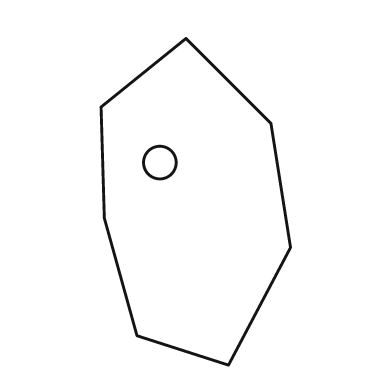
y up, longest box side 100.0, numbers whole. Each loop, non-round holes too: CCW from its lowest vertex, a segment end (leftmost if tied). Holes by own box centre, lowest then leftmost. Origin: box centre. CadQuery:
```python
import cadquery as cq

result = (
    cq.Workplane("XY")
    .moveTo(10.0, -50.0)
    .lineTo(29.0, -14.0)
    .lineTo(23.0, 24.0)
    .lineTo(-3.0, 50.0)
    .lineTo(-29.0, 29.0)
    .lineTo(-28.0, -5.0)
    .lineTo(-18.0, -41.0)
    .close()
    .moveTo(-11.0, 12.0)
    .circle(5.0)
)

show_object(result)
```